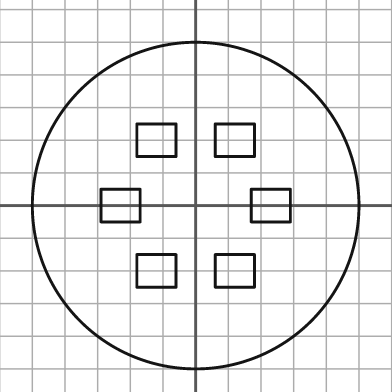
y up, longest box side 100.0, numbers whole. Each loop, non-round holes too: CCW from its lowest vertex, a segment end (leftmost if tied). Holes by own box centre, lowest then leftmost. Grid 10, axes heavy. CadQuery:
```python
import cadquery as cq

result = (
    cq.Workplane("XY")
    .moveTo(0.0, 0.0)
    .circle(50.0)
    .moveTo(-18.0, -25.0)
    .lineTo(-6.0, -25.0)
    .lineTo(-6.0, -15.0)
    .lineTo(-18.0, -15.0)
    .close()
    .moveTo(6.0, -25.0)
    .lineTo(18.0, -25.0)
    .lineTo(18.0, -15.0)
    .lineTo(6.0, -15.0)
    .close()
    .moveTo(-29.0, -5.0)
    .lineTo(-17.0, -5.0)
    .lineTo(-17.0, 5.0)
    .lineTo(-29.0, 5.0)
    .close()
    .moveTo(17.0, -5.0)
    .lineTo(29.0, -5.0)
    .lineTo(29.0, 5.0)
    .lineTo(17.0, 5.0)
    .close()
    .moveTo(-18.0, 15.0)
    .lineTo(-6.0, 15.0)
    .lineTo(-6.0, 25.0)
    .lineTo(-18.0, 25.0)
    .close()
    .moveTo(6.0, 15.0)
    .lineTo(18.0, 15.0)
    .lineTo(18.0, 25.0)
    .lineTo(6.0, 25.0)
    .close()
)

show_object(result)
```